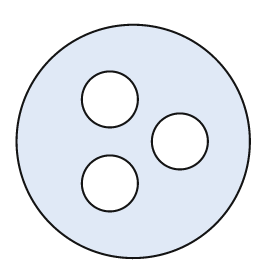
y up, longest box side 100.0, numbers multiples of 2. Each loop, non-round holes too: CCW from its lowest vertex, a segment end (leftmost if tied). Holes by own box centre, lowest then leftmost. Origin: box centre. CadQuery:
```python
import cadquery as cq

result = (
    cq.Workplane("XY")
    .moveTo(0.0, 0.0)
    .circle(50.0)
    .moveTo(-10.0, -18.0)
    .circle(12.0)
    .moveTo(20.0, 0.0)
    .circle(12.0)
    .moveTo(-10.0, 18.0)
    .circle(12.0)
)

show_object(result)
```